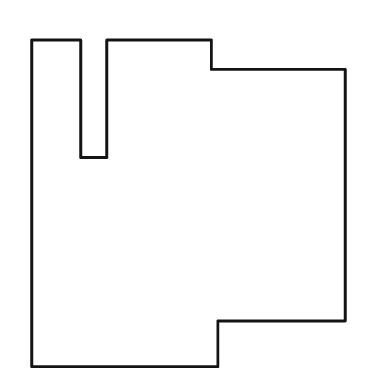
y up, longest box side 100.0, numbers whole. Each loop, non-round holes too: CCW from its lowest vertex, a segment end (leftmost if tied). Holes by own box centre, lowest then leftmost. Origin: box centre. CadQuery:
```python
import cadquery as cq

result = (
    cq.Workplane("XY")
    .moveTo(-48.0, -50.0)
    .lineTo(9.0, -50.0)
    .lineTo(9.0, -36.0)
    .lineTo(48.0, -36.0)
    .lineTo(48.0, 41.0)
    .lineTo(7.0, 41.0)
    .lineTo(7.0, 50.0)
    .lineTo(-25.0, 50.0)
    .lineTo(-25.0, 14.0)
    .lineTo(-33.0, 14.0)
    .lineTo(-33.0, 50.0)
    .lineTo(-48.0, 50.0)
    .close()
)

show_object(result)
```